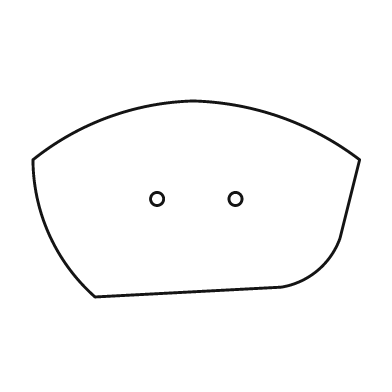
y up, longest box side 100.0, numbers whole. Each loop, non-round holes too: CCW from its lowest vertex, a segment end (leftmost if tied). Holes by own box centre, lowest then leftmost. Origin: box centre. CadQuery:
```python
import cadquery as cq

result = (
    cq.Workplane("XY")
    .moveTo(-31.0, -30.0)
    .lineTo(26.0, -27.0)
    .threePointArc((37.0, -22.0), (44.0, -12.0))
    .lineTo(50.0, 12.0)
    .threePointArc((26.0, 25.0), (-1.0, 30.0))
    .threePointArc((-27.0, 25.0), (-50.0, 12.0))
    .threePointArc((-45.0, -11.0), (-31.0, -30.0))
    .close()
    .moveTo(-12.0, 0.0)
    .circle(2.0)
    .moveTo(12.0, 0.0)
    .circle(2.0)
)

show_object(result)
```